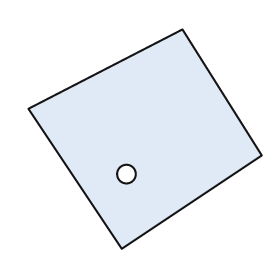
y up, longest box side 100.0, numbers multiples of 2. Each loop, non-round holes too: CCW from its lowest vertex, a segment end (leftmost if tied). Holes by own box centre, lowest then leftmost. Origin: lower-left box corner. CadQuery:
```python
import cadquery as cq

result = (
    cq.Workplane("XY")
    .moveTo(40.0, 0.0)
    .lineTo(100.0, 40.0)
    .lineTo(66.0, 94.0)
    .lineTo(0.0, 60.0)
    .close()
    .moveTo(42.0, 32.0)
    .circle(4.0)
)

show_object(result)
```